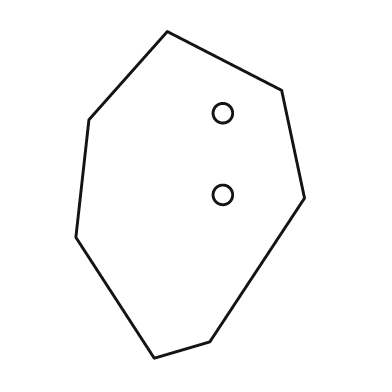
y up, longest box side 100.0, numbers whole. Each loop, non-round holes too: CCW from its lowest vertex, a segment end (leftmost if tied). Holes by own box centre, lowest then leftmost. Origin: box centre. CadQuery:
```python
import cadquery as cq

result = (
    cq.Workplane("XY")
    .moveTo(-11.0, -50.0)
    .lineTo(6.0, -45.0)
    .lineTo(35.0, -1.0)
    .lineTo(28.0, 32.0)
    .lineTo(-7.0, 50.0)
    .lineTo(-31.0, 23.0)
    .lineTo(-35.0, -13.0)
    .close()
    .moveTo(10.0, 0.0)
    .circle(3.0)
    .moveTo(10.0, 25.0)
    .circle(3.0)
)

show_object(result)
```